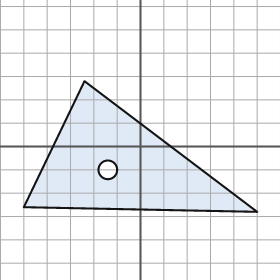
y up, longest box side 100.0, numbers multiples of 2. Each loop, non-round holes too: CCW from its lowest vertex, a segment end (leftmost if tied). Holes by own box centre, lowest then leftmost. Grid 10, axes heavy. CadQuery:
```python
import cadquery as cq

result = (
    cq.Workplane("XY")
    .moveTo(50.0, -28.0)
    .lineTo(-24.0, 28.0)
    .lineTo(-50.0, -26.0)
    .close()
    .moveTo(-14.0, -10.0)
    .circle(4.0)
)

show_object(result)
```